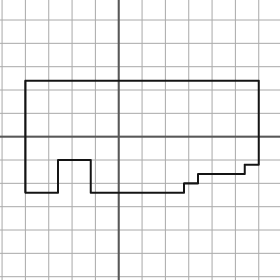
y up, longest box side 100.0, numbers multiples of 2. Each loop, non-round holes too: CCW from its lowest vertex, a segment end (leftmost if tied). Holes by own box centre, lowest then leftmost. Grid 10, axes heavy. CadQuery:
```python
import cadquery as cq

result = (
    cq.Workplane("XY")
    .moveTo(-40.0, -24.0)
    .lineTo(-26.0, -24.0)
    .lineTo(-26.0, -10.0)
    .lineTo(-12.0, -10.0)
    .lineTo(-12.0, -24.0)
    .lineTo(28.0, -24.0)
    .lineTo(28.0, -20.0)
    .lineTo(34.0, -20.0)
    .lineTo(34.0, -16.0)
    .lineTo(54.0, -16.0)
    .lineTo(54.0, -12.0)
    .lineTo(60.0, -12.0)
    .lineTo(60.0, 24.0)
    .lineTo(-40.0, 24.0)
    .close()
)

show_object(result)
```